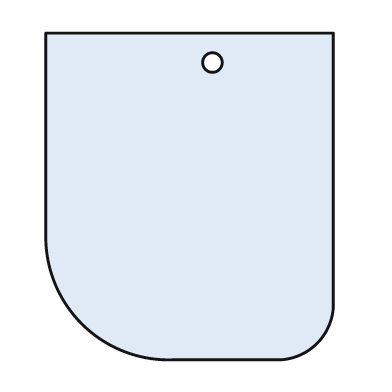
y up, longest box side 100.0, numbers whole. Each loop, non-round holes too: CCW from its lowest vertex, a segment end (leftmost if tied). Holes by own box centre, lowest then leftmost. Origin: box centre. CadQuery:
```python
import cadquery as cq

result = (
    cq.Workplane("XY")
    .moveTo(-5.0, -50.0)
    .lineTo(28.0, -50.0)
    .threePointArc((39.0, -45.0), (44.0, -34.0))
    .lineTo(44.0, 50.0)
    .lineTo(-44.0, 50.0)
    .lineTo(-44.0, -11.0)
    .threePointArc((-33.0, -39.0), (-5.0, -50.0))
    .close()
    .moveTo(7.0, 41.0)
    .circle(3.0)
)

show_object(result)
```